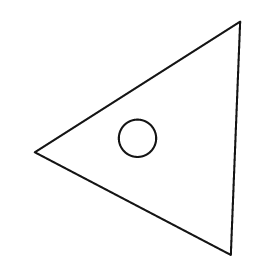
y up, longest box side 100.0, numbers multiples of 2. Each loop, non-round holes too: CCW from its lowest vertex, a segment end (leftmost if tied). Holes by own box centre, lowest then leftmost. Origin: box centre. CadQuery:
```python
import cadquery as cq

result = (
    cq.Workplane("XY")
    .moveTo(40.0, -50.0)
    .lineTo(44.0, 50.0)
    .lineTo(-44.0, -6.0)
    .close()
    .moveTo(0.0, 0.0)
    .circle(8.0)
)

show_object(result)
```